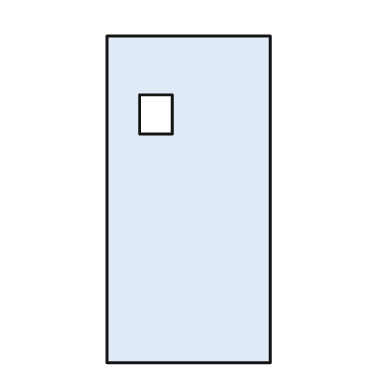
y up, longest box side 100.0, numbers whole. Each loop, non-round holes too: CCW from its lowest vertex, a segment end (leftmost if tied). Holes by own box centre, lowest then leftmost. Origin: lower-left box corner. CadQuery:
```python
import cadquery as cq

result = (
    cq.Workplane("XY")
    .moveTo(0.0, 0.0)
    .lineTo(50.0, 0.0)
    .lineTo(50.0, 100.0)
    .lineTo(0.0, 100.0)
    .close()
    .moveTo(10.0, 70.0)
    .lineTo(20.0, 70.0)
    .lineTo(20.0, 82.0)
    .lineTo(10.0, 82.0)
    .close()
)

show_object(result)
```